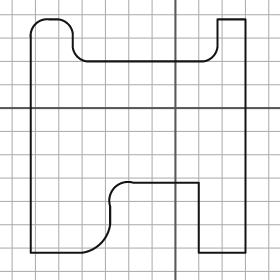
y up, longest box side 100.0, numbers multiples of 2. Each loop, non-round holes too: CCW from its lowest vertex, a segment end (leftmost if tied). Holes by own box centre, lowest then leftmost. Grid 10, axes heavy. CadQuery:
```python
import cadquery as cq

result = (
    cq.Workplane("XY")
    .moveTo(-62.0, -62.0)
    .lineTo(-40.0, -62.0)
    .threePointArc((-32.0, -58.0), (-28.0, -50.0))
    .lineTo(-28.0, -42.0)
    .threePointArc((-26.0, -34.0), (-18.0, -32.0))
    .lineTo(10.0, -32.0)
    .lineTo(10.0, -62.0)
    .lineTo(30.0, -62.0)
    .lineTo(30.0, 38.0)
    .lineTo(18.0, 38.0)
    .lineTo(18.0, 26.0)
    .threePointArc((16.0, 22.0), (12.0, 20.0))
    .lineTo(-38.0, 20.0)
    .threePointArc((-42.0, 22.0), (-44.0, 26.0))
    .lineTo(-44.0, 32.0)
    .threePointArc((-46.0, 36.0), (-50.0, 38.0))
    .lineTo(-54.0, 38.0)
    .threePointArc((-60.0, 36.0), (-62.0, 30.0))
    .close()
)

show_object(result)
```